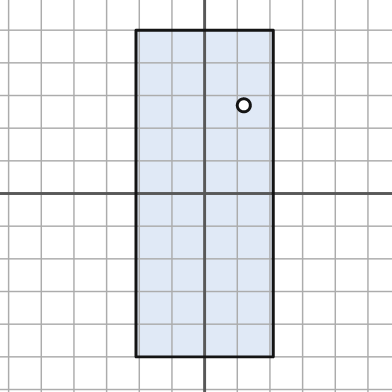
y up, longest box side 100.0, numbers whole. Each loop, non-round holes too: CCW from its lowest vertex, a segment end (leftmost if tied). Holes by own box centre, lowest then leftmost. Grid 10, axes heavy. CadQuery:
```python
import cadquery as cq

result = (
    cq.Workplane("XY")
    .moveTo(-21.0, -50.0)
    .lineTo(21.0, -50.0)
    .lineTo(21.0, 50.0)
    .lineTo(-21.0, 50.0)
    .close()
    .moveTo(12.0, 27.0)
    .circle(2.0)
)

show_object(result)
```